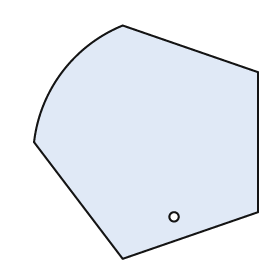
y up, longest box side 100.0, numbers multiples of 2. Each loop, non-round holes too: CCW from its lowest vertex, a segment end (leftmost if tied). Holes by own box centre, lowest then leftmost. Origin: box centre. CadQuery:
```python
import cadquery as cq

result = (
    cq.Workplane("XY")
    .moveTo(-10.0, -50.0)
    .lineTo(48.0, -30.0)
    .lineTo(48.0, 30.0)
    .lineTo(-10.0, 50.0)
    .threePointArc((-36.0, 30.0), (-48.0, 0.0))
    .close()
    .moveTo(12.0, -32.0)
    .circle(2.0)
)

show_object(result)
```